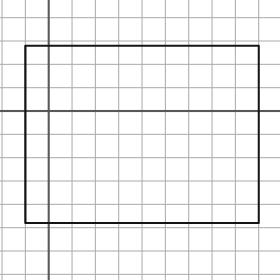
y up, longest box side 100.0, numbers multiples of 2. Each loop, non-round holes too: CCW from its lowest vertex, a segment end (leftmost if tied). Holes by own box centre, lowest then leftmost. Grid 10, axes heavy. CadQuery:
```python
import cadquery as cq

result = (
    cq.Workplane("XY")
    .moveTo(-10.0, -48.0)
    .lineTo(90.0, -48.0)
    .lineTo(90.0, 28.0)
    .lineTo(-10.0, 28.0)
    .close()
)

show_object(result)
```